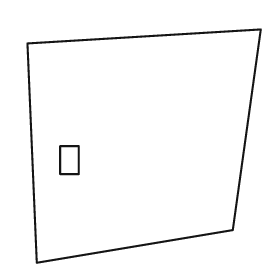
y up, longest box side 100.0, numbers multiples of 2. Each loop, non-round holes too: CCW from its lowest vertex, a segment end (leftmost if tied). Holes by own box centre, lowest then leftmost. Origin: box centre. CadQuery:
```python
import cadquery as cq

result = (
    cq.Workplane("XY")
    .moveTo(-46.0, -50.0)
    .lineTo(38.0, -36.0)
    .lineTo(50.0, 50.0)
    .lineTo(-50.0, 44.0)
    .close()
    .moveTo(-36.0, -12.0)
    .lineTo(-28.0, -12.0)
    .lineTo(-28.0, 0.0)
    .lineTo(-36.0, 0.0)
    .close()
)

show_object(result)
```